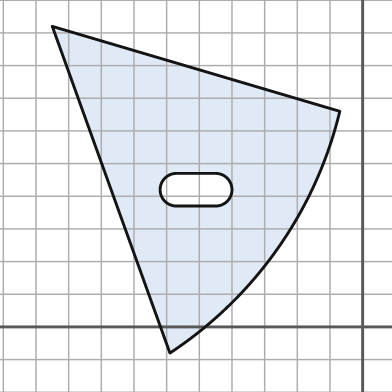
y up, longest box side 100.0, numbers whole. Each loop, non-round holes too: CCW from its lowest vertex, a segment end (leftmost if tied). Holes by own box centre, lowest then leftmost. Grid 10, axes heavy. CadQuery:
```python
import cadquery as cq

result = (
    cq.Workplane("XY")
    .moveTo(-59.0, -8.0)
    .threePointArc((-26.0, 24.0), (-7.0, 66.0))
    .lineTo(-95.0, 92.0)
    .close()
    .moveTo(-57.0, 37.0)
    .lineTo(-45.0, 37.0)
    .threePointArc((-40.0, 42.0), (-45.0, 47.0))
    .lineTo(-57.0, 47.0)
    .threePointArc((-62.0, 42.0), (-57.0, 37.0))
    .close()
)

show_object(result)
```